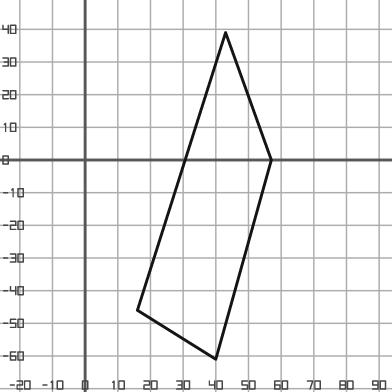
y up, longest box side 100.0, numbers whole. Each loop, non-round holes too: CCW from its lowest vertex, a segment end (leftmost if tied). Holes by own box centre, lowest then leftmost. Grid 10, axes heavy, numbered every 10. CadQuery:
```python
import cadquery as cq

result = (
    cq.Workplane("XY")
    .moveTo(40.0, -61.0)
    .lineTo(57.0, 0.0)
    .lineTo(43.0, 39.0)
    .lineTo(16.0, -46.0)
    .close()
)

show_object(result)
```